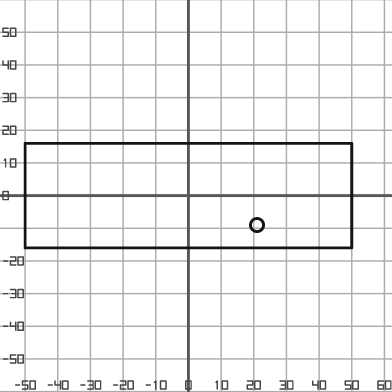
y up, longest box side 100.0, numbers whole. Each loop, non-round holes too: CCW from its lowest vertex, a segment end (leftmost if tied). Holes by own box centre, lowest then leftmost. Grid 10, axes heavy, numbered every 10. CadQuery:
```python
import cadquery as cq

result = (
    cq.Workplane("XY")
    .moveTo(-50.0, -16.0)
    .lineTo(50.0, -16.0)
    .lineTo(50.0, 16.0)
    .lineTo(-50.0, 16.0)
    .close()
    .moveTo(21.0, -9.0)
    .circle(2.0)
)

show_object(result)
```